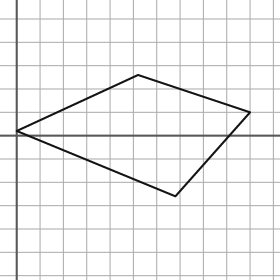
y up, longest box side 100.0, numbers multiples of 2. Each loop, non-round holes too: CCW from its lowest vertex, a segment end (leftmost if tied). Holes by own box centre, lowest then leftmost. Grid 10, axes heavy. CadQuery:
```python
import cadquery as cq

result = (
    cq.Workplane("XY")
    .moveTo(68.0, -26.0)
    .lineTo(100.0, 10.0)
    .lineTo(52.0, 26.0)
    .lineTo(0.0, 2.0)
    .close()
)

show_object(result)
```